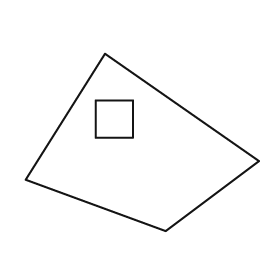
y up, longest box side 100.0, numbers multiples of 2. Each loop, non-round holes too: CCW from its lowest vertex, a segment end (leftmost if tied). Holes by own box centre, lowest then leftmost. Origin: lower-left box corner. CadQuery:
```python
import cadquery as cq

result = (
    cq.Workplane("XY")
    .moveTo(60.0, 0.0)
    .lineTo(100.0, 30.0)
    .lineTo(34.0, 76.0)
    .lineTo(0.0, 22.0)
    .close()
    .moveTo(30.0, 40.0)
    .lineTo(46.0, 40.0)
    .lineTo(46.0, 56.0)
    .lineTo(30.0, 56.0)
    .close()
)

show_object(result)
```